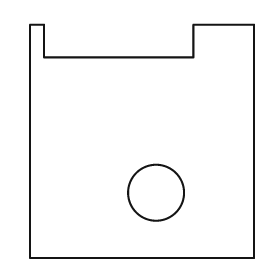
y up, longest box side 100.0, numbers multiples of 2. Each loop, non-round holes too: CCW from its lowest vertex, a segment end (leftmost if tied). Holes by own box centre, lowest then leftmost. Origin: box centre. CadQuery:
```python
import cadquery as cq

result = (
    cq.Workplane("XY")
    .moveTo(-48.0, -50.0)
    .lineTo(48.0, -50.0)
    .lineTo(48.0, 50.0)
    .lineTo(22.0, 50.0)
    .lineTo(22.0, 36.0)
    .lineTo(-42.0, 36.0)
    .lineTo(-42.0, 50.0)
    .lineTo(-48.0, 50.0)
    .close()
    .moveTo(6.0, -22.0)
    .circle(12.0)
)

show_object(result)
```